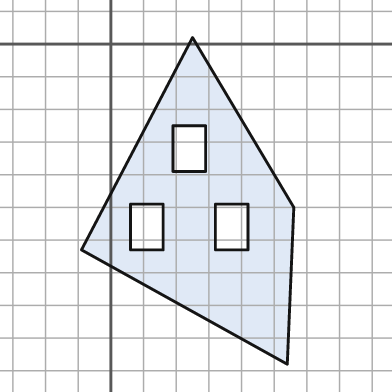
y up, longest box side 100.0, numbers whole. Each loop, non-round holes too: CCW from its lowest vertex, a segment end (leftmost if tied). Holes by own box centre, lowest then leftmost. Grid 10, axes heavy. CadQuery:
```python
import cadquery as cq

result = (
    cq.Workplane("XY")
    .moveTo(54.0, -98.0)
    .lineTo(56.0, -50.0)
    .lineTo(25.0, 2.0)
    .lineTo(-9.0, -63.0)
    .close()
    .moveTo(6.0, -63.0)
    .lineTo(16.0, -63.0)
    .lineTo(16.0, -49.0)
    .lineTo(6.0, -49.0)
    .close()
    .moveTo(32.0, -63.0)
    .lineTo(42.0, -63.0)
    .lineTo(42.0, -49.0)
    .lineTo(32.0, -49.0)
    .close()
    .moveTo(19.0, -39.0)
    .lineTo(29.0, -39.0)
    .lineTo(29.0, -25.0)
    .lineTo(19.0, -25.0)
    .close()
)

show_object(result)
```